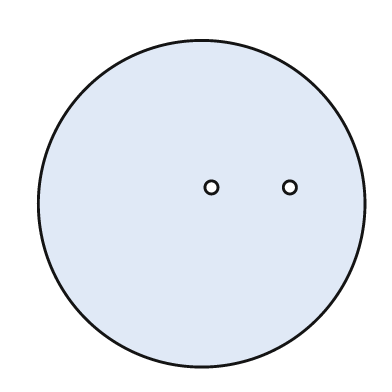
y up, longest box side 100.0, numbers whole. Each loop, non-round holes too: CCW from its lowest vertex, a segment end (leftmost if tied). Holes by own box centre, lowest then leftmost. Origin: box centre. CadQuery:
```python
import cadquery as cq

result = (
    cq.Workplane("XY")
    .moveTo(0.0, 0.0)
    .circle(50.0)
    .moveTo(3.0, 5.0)
    .circle(2.0)
    .moveTo(27.0, 5.0)
    .circle(2.0)
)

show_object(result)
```